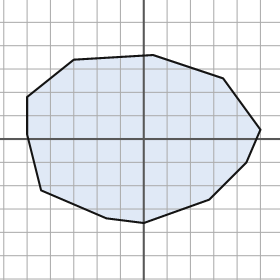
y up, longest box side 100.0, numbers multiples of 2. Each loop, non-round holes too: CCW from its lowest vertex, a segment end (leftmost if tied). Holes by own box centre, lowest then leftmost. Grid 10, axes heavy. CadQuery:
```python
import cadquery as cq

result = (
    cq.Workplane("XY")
    .moveTo(0.0, -36.0)
    .lineTo(28.0, -26.0)
    .lineTo(44.0, -10.0)
    .lineTo(50.0, 4.0)
    .lineTo(34.0, 26.0)
    .lineTo(4.0, 36.0)
    .lineTo(-30.0, 34.0)
    .lineTo(-50.0, 18.0)
    .lineTo(-50.0, 2.0)
    .lineTo(-44.0, -22.0)
    .lineTo(-16.0, -34.0)
    .close()
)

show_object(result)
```